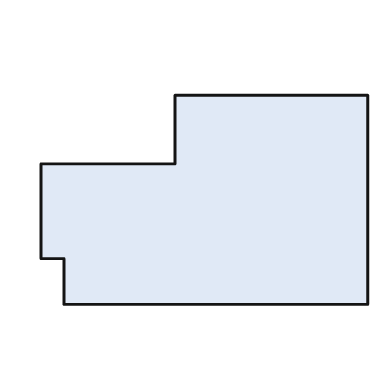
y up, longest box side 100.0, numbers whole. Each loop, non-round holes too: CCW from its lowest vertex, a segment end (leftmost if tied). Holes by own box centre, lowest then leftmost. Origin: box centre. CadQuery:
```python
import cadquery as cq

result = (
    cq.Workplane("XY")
    .moveTo(-43.0, -32.0)
    .lineTo(50.0, -32.0)
    .lineTo(50.0, 32.0)
    .lineTo(-9.0, 32.0)
    .lineTo(-9.0, 11.0)
    .lineTo(-50.0, 11.0)
    .lineTo(-50.0, -18.0)
    .lineTo(-43.0, -18.0)
    .close()
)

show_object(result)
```